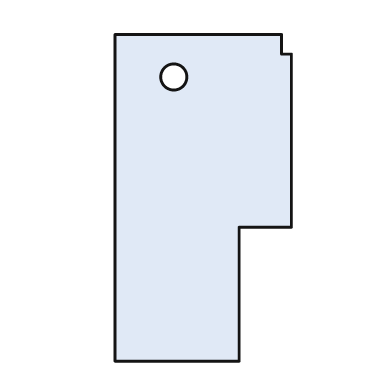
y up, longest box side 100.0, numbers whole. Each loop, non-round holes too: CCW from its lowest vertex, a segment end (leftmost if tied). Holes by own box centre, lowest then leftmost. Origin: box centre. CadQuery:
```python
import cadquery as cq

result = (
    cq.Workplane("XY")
    .moveTo(-27.0, -50.0)
    .lineTo(11.0, -50.0)
    .lineTo(11.0, -9.0)
    .lineTo(27.0, -9.0)
    .lineTo(27.0, 44.0)
    .lineTo(24.0, 44.0)
    .lineTo(24.0, 50.0)
    .lineTo(-27.0, 50.0)
    .close()
    .moveTo(-9.0, 37.0)
    .circle(4.0)
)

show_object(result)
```